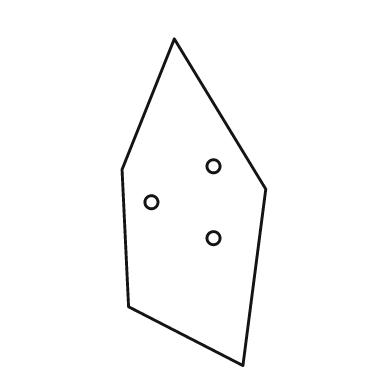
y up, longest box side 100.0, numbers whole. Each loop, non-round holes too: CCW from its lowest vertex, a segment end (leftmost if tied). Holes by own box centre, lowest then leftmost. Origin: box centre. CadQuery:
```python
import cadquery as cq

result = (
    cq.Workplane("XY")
    .moveTo(15.0, -50.0)
    .lineTo(22.0, 4.0)
    .lineTo(-6.0, 50.0)
    .lineTo(-22.0, 10.0)
    .lineTo(-20.0, -32.0)
    .close()
    .moveTo(6.0, -11.0)
    .circle(2.0)
    .moveTo(-13.0, 0.0)
    .circle(2.0)
    .moveTo(6.0, 11.0)
    .circle(2.0)
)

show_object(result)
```